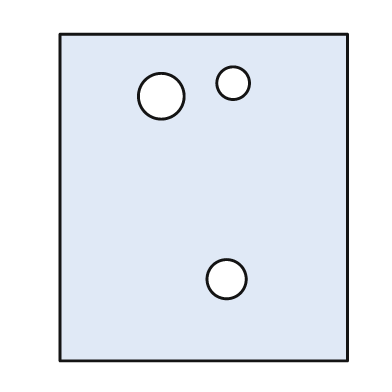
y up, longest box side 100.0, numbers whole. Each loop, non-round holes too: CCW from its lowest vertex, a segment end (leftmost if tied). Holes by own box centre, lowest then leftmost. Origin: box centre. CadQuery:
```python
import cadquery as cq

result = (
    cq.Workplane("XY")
    .moveTo(-44.0, -50.0)
    .lineTo(44.0, -50.0)
    .lineTo(44.0, 50.0)
    .lineTo(-44.0, 50.0)
    .close()
    .moveTo(7.0, -25.0)
    .circle(6.0)
    .moveTo(-13.0, 31.0)
    .circle(7.0)
    .moveTo(9.0, 35.0)
    .circle(5.0)
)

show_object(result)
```